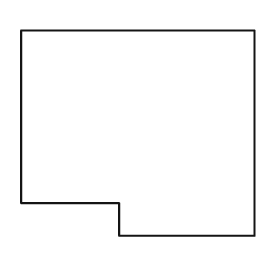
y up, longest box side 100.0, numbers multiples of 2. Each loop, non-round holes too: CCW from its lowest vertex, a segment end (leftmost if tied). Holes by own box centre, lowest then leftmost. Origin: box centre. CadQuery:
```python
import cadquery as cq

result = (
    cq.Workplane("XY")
    .moveTo(-8.0, -44.0)
    .lineTo(50.0, -44.0)
    .lineTo(50.0, 44.0)
    .lineTo(-50.0, 44.0)
    .lineTo(-50.0, -30.0)
    .lineTo(-8.0, -30.0)
    .close()
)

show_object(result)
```